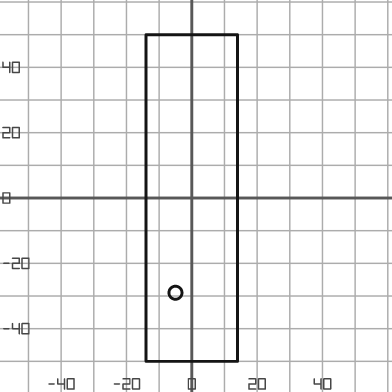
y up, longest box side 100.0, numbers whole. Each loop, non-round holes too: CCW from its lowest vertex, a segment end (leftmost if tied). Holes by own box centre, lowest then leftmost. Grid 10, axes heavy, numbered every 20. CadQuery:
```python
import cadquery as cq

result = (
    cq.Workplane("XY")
    .moveTo(-14.0, -50.0)
    .lineTo(14.0, -50.0)
    .lineTo(14.0, 50.0)
    .lineTo(-14.0, 50.0)
    .close()
    .moveTo(-5.0, -29.0)
    .circle(2.0)
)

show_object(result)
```